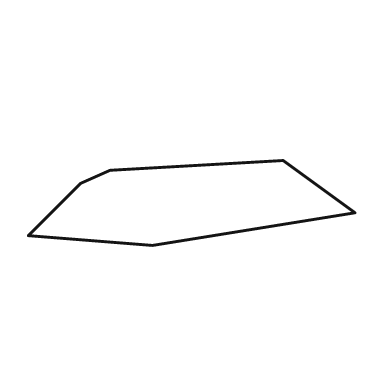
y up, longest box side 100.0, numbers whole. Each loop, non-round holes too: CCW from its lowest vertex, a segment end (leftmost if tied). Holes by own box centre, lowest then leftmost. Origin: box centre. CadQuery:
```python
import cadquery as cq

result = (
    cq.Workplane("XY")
    .moveTo(-12.0, -13.0)
    .lineTo(50.0, -3.0)
    .lineTo(28.0, 13.0)
    .lineTo(-25.0, 10.0)
    .lineTo(-34.0, 6.0)
    .lineTo(-50.0, -10.0)
    .close()
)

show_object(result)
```